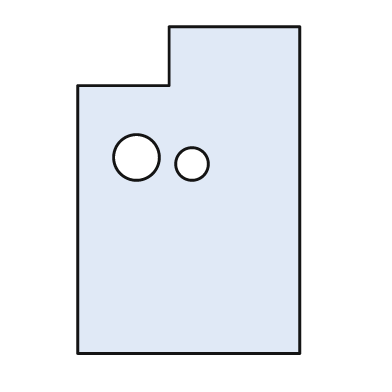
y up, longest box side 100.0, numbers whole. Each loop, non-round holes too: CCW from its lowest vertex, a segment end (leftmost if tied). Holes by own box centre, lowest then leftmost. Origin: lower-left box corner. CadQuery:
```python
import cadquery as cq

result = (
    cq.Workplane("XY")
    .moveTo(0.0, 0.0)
    .lineTo(68.0, 0.0)
    .lineTo(68.0, 100.0)
    .lineTo(28.0, 100.0)
    .lineTo(28.0, 82.0)
    .lineTo(0.0, 82.0)
    .close()
    .moveTo(35.0, 58.0)
    .circle(5.0)
    .moveTo(18.0, 60.0)
    .circle(7.0)
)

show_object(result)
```